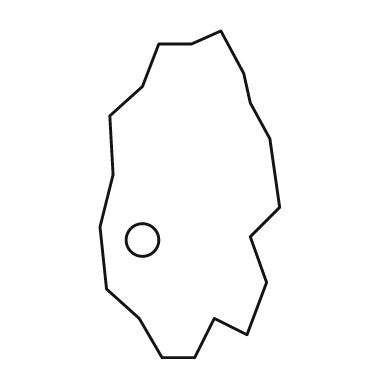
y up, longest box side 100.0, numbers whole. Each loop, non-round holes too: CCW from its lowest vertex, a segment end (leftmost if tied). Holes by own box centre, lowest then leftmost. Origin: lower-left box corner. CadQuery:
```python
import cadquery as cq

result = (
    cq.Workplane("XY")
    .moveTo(19.0, 0.0)
    .lineTo(29.0, 0.0)
    .lineTo(35.0, 12.0)
    .lineTo(45.0, 7.0)
    .lineTo(51.0, 23.0)
    .lineTo(46.0, 37.0)
    .lineTo(55.0, 46.0)
    .lineTo(52.0, 67.0)
    .lineTo(46.0, 78.0)
    .lineTo(44.0, 87.0)
    .lineTo(37.0, 100.0)
    .lineTo(28.0, 96.0)
    .lineTo(18.0, 96.0)
    .lineTo(13.0, 83.0)
    .lineTo(3.0, 74.0)
    .lineTo(4.0, 56.0)
    .lineTo(0.0, 40.0)
    .lineTo(2.0, 21.0)
    .lineTo(12.0, 12.0)
    .close()
    .moveTo(13.0, 36.0)
    .circle(5.0)
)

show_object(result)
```